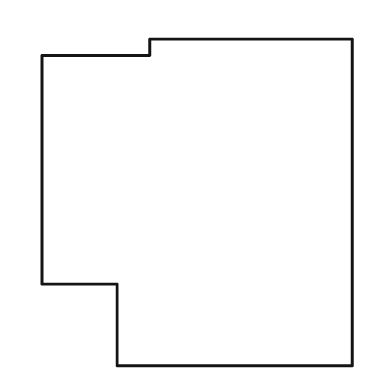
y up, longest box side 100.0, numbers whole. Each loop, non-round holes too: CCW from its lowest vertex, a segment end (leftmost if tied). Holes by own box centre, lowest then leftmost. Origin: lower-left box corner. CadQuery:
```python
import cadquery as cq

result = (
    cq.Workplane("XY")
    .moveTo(23.0, 0.0)
    .lineTo(95.0, 0.0)
    .lineTo(95.0, 100.0)
    .lineTo(33.0, 100.0)
    .lineTo(33.0, 95.0)
    .lineTo(0.0, 95.0)
    .lineTo(0.0, 25.0)
    .lineTo(23.0, 25.0)
    .close()
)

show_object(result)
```